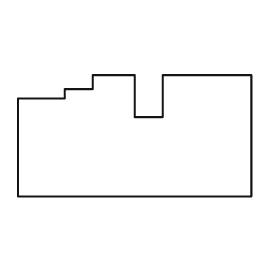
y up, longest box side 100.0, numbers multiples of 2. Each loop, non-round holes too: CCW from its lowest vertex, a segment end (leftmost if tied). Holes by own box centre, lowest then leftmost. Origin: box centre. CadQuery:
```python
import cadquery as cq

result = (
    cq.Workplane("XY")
    .moveTo(-50.0, -26.0)
    .lineTo(50.0, -26.0)
    .lineTo(50.0, 26.0)
    .lineTo(12.0, 26.0)
    .lineTo(12.0, 8.0)
    .lineTo(0.0, 8.0)
    .lineTo(0.0, 26.0)
    .lineTo(-18.0, 26.0)
    .lineTo(-18.0, 20.0)
    .lineTo(-30.0, 20.0)
    .lineTo(-30.0, 16.0)
    .lineTo(-50.0, 16.0)
    .close()
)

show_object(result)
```